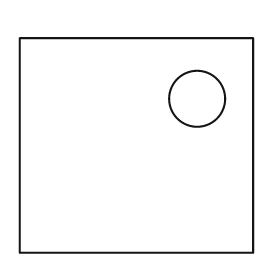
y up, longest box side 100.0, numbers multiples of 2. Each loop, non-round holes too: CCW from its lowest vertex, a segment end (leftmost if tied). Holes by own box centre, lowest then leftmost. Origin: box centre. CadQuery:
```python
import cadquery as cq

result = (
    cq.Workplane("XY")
    .moveTo(-50.0, -46.0)
    .lineTo(50.0, -46.0)
    .lineTo(50.0, 46.0)
    .lineTo(-50.0, 46.0)
    .close()
    .moveTo(26.0, 20.0)
    .circle(12.0)
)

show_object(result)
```